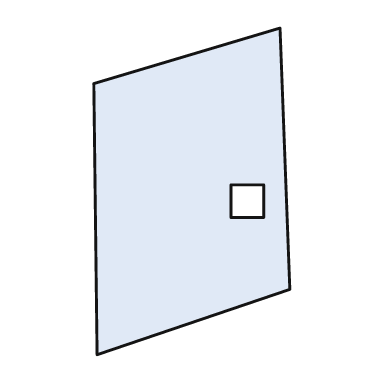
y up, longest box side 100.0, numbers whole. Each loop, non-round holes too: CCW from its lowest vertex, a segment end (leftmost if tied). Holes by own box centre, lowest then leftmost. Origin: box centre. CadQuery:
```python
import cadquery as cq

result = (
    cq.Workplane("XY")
    .moveTo(-29.0, -50.0)
    .lineTo(30.0, -30.0)
    .lineTo(27.0, 50.0)
    .lineTo(-30.0, 33.0)
    .close()
    .moveTo(12.0, -8.0)
    .lineTo(22.0, -8.0)
    .lineTo(22.0, 2.0)
    .lineTo(12.0, 2.0)
    .close()
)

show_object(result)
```